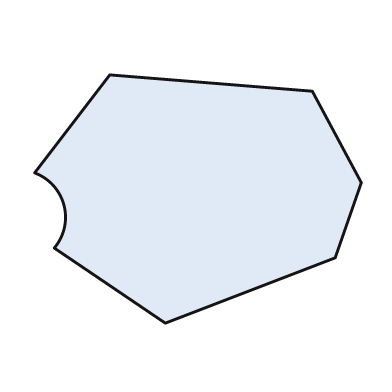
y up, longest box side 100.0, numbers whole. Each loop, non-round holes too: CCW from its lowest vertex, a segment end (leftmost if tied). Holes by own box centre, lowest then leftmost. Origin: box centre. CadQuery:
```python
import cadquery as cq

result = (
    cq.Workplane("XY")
    .moveTo(-10.0, -38.0)
    .lineTo(42.0, -18.0)
    .lineTo(50.0, 5.0)
    .lineTo(35.0, 33.0)
    .lineTo(-27.0, 38.0)
    .lineTo(-50.0, 8.0)
    .threePointArc((-41.0, -2.0), (-44.0, -15.0))
    .close()
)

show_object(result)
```